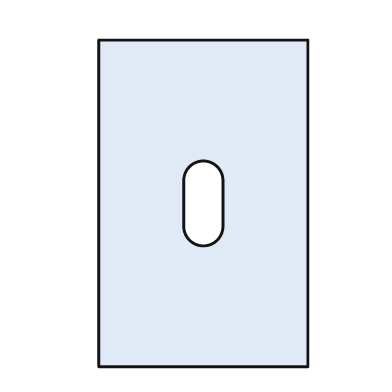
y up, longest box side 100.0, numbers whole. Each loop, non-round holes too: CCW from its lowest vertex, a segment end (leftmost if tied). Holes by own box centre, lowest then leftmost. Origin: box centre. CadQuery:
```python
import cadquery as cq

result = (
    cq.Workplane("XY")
    .moveTo(-32.0, -50.0)
    .lineTo(32.0, -50.0)
    .lineTo(32.0, 50.0)
    .lineTo(-32.0, 50.0)
    .close()
    .moveTo(-6.0, -7.0)
    .threePointArc((0.0, -13.0), (6.0, -7.0))
    .lineTo(6.0, 7.0)
    .threePointArc((0.0, 13.0), (-6.0, 7.0))
    .close()
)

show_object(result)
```